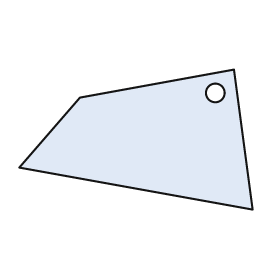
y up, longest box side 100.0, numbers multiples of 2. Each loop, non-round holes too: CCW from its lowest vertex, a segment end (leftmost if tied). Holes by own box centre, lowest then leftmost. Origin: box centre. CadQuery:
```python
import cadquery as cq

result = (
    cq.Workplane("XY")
    .moveTo(50.0, -30.0)
    .lineTo(42.0, 30.0)
    .lineTo(-24.0, 18.0)
    .lineTo(-50.0, -12.0)
    .close()
    .moveTo(34.0, 20.0)
    .circle(4.0)
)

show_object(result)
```